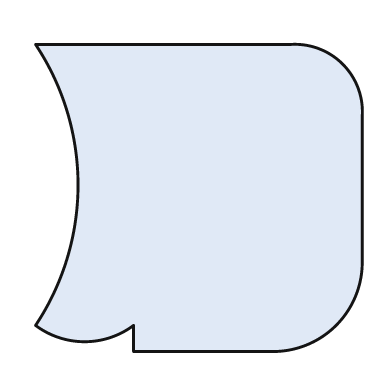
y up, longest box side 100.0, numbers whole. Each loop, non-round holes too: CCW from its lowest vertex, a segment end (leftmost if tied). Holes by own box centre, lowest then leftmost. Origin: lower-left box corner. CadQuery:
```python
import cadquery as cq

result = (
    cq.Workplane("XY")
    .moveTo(30.0, 0.0)
    .lineTo(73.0, 0.0)
    .threePointArc((92.0, 8.0), (100.0, 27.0))
    .lineTo(100.0, 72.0)
    .threePointArc((94.0, 88.0), (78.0, 94.0))
    .lineTo(0.0, 94.0)
    .threePointArc((13.0, 51.0), (0.0, 8.0))
    .threePointArc((15.0, 3.0), (30.0, 8.0))
    .close()
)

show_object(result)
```